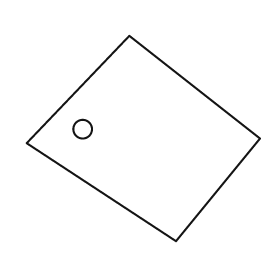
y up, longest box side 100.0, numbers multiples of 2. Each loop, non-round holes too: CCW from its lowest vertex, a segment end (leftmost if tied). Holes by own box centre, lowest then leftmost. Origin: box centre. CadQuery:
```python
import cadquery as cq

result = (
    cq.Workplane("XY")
    .moveTo(14.0, -44.0)
    .lineTo(50.0, 0.0)
    .lineTo(-6.0, 44.0)
    .lineTo(-50.0, -2.0)
    .close()
    .moveTo(-26.0, 4.0)
    .circle(4.0)
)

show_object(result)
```